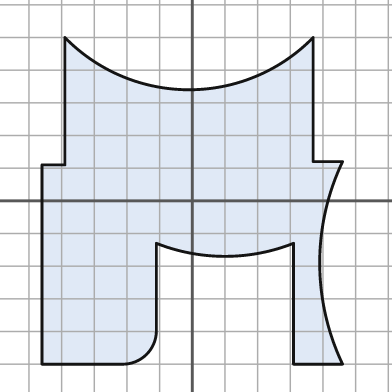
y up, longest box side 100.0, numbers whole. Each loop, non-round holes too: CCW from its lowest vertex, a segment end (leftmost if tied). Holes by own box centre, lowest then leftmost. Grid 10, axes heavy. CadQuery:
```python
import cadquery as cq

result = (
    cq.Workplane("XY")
    .moveTo(-46.0, -50.0)
    .lineTo(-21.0, -50.0)
    .threePointArc((-14.0, -47.0), (-11.0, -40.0))
    .lineTo(-11.0, -13.0)
    .threePointArc((10.0, -17.0), (31.0, -13.0))
    .lineTo(31.0, -50.0)
    .lineTo(46.0, -50.0)
    .threePointArc((39.0, -19.0), (46.0, 12.0))
    .lineTo(37.0, 12.0)
    .lineTo(37.0, 50.0)
    .threePointArc((-1.0, 34.0), (-39.0, 50.0))
    .lineTo(-39.0, 11.0)
    .lineTo(-46.0, 11.0)
    .close()
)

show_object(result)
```